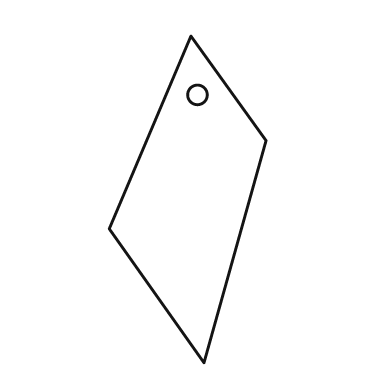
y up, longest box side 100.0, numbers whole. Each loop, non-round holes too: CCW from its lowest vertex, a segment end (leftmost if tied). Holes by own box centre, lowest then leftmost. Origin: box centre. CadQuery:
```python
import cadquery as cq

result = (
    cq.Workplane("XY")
    .moveTo(5.0, -50.0)
    .lineTo(24.0, 18.0)
    .lineTo(1.0, 50.0)
    .lineTo(-24.0, -9.0)
    .close()
    .moveTo(3.0, 32.0)
    .circle(3.0)
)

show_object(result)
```